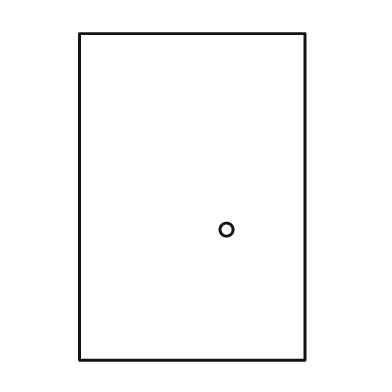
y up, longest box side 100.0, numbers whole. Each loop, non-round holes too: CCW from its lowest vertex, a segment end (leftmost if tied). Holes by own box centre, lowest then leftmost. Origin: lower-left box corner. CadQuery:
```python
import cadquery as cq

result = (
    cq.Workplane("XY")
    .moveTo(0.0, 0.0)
    .lineTo(69.0, 0.0)
    .lineTo(69.0, 100.0)
    .lineTo(0.0, 100.0)
    .close()
    .moveTo(45.0, 40.0)
    .circle(2.0)
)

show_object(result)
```